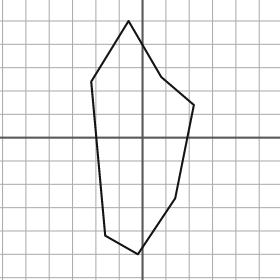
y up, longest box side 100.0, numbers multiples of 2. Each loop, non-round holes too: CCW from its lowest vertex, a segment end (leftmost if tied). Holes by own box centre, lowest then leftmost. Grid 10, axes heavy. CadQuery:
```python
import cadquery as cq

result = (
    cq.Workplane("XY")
    .moveTo(-2.0, -50.0)
    .lineTo(14.0, -26.0)
    .lineTo(22.0, 14.0)
    .lineTo(8.0, 26.0)
    .lineTo(-6.0, 50.0)
    .lineTo(-22.0, 24.0)
    .lineTo(-16.0, -42.0)
    .close()
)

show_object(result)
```